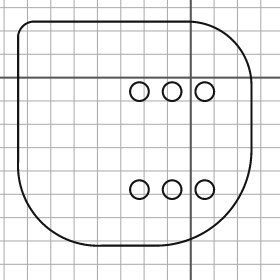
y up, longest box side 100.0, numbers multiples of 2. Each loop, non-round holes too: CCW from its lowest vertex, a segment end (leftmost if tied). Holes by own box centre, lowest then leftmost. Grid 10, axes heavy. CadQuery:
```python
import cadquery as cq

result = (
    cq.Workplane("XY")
    .moveTo(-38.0, -72.0)
    .lineTo(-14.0, -72.0)
    .threePointArc((14.0, -60.0), (26.0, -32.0))
    .lineTo(26.0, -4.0)
    .threePointArc((18.0, 16.0), (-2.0, 24.0))
    .lineTo(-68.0, 24.0)
    .threePointArc((-72.0, 22.0), (-74.0, 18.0))
    .lineTo(-74.0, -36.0)
    .threePointArc((-64.0, -62.0), (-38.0, -72.0))
    .close()
    .moveTo(-22.0, -48.0)
    .circle(4.0)
    .moveTo(-8.0, -48.0)
    .circle(4.0)
    .moveTo(6.0, -48.0)
    .circle(4.0)
    .moveTo(-22.0, -6.0)
    .circle(4.0)
    .moveTo(-8.0, -6.0)
    .circle(4.0)
    .moveTo(6.0, -6.0)
    .circle(4.0)
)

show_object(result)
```